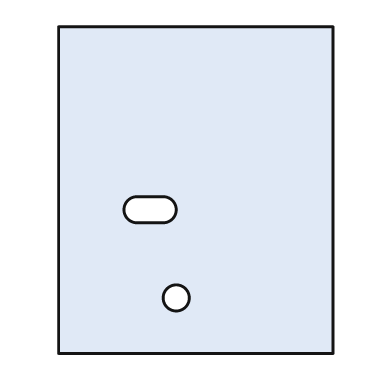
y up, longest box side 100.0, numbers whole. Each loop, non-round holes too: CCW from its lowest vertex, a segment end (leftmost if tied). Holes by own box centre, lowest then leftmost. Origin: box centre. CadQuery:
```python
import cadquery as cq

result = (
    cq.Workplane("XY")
    .moveTo(-42.0, -50.0)
    .lineTo(42.0, -50.0)
    .lineTo(42.0, 50.0)
    .lineTo(-42.0, 50.0)
    .close()
    .moveTo(-6.0, -33.0)
    .circle(4.0)
    .moveTo(-18.0, -10.0)
    .lineTo(-10.0, -10.0)
    .threePointArc((-6.0, -6.0), (-10.0, -2.0))
    .lineTo(-18.0, -2.0)
    .threePointArc((-22.0, -6.0), (-18.0, -10.0))
    .close()
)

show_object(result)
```